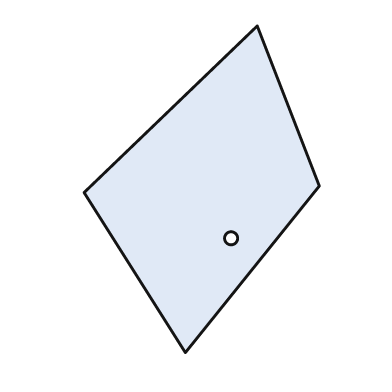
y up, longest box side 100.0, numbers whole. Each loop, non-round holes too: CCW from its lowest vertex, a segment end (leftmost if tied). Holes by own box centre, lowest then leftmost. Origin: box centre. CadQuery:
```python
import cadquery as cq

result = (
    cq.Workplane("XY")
    .moveTo(-5.0, -50.0)
    .lineTo(36.0, 1.0)
    .lineTo(17.0, 50.0)
    .lineTo(-36.0, -1.0)
    .close()
    .moveTo(9.0, -15.0)
    .circle(2.0)
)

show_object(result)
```